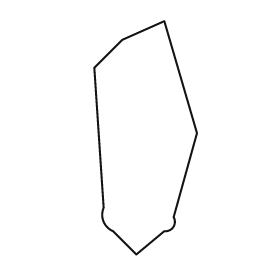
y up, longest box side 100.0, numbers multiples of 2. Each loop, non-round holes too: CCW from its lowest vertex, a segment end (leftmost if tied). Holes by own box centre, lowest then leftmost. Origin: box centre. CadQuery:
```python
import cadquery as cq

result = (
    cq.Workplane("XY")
    .moveTo(-4.0, -50.0)
    .lineTo(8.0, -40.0)
    .threePointArc((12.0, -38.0), (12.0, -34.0))
    .lineTo(22.0, 2.0)
    .lineTo(8.0, 50.0)
    .lineTo(-10.0, 42.0)
    .lineTo(-22.0, 30.0)
    .lineTo(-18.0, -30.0)
    .threePointArc((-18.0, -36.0), (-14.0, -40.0))
    .close()
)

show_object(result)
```